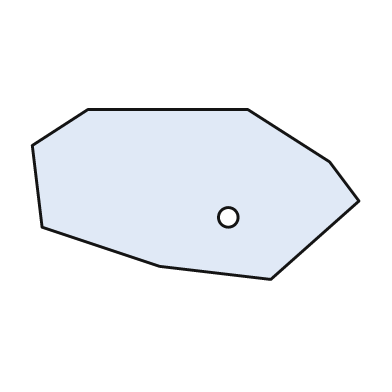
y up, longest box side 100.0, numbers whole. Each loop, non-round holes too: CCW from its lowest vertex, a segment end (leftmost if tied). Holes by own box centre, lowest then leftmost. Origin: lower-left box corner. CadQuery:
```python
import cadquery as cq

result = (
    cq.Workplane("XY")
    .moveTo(73.0, 0.0)
    .lineTo(100.0, 24.0)
    .lineTo(91.0, 36.0)
    .lineTo(66.0, 52.0)
    .lineTo(17.0, 52.0)
    .lineTo(0.0, 41.0)
    .lineTo(3.0, 16.0)
    .lineTo(39.0, 4.0)
    .close()
    .moveTo(60.0, 19.0)
    .circle(3.0)
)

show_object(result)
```